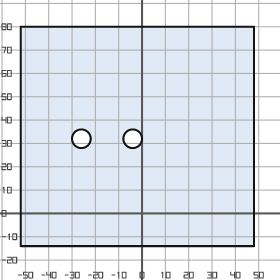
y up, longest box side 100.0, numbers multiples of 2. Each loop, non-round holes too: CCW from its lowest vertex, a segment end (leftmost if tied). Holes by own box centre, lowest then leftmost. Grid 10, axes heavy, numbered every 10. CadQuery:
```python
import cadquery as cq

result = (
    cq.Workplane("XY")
    .moveTo(-52.0, -14.0)
    .lineTo(48.0, -14.0)
    .lineTo(48.0, 80.0)
    .lineTo(-52.0, 80.0)
    .close()
    .moveTo(-26.0, 32.0)
    .circle(4.0)
    .moveTo(-4.0, 32.0)
    .circle(4.0)
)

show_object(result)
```